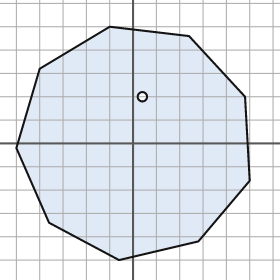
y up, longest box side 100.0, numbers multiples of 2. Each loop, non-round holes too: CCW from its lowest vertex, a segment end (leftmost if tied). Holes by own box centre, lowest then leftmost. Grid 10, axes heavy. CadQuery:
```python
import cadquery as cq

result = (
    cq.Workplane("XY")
    .moveTo(-6.0, -50.0)
    .lineTo(28.0, -42.0)
    .lineTo(50.0, -16.0)
    .lineTo(48.0, 20.0)
    .lineTo(24.0, 46.0)
    .lineTo(-10.0, 50.0)
    .lineTo(-40.0, 32.0)
    .lineTo(-50.0, -2.0)
    .lineTo(-36.0, -34.0)
    .close()
    .moveTo(4.0, 20.0)
    .circle(2.0)
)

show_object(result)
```